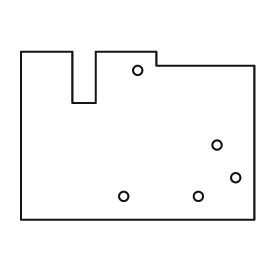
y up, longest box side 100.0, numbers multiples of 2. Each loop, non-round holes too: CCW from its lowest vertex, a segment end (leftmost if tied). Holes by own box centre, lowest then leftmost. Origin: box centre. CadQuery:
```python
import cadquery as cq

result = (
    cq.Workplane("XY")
    .moveTo(-50.0, -36.0)
    .lineTo(50.0, -36.0)
    .lineTo(50.0, 30.0)
    .lineTo(8.0, 30.0)
    .lineTo(8.0, 36.0)
    .lineTo(-18.0, 36.0)
    .lineTo(-18.0, 14.0)
    .lineTo(-28.0, 14.0)
    .lineTo(-28.0, 36.0)
    .lineTo(-50.0, 36.0)
    .close()
    .moveTo(-6.0, -26.0)
    .circle(2.0)
    .moveTo(26.0, -26.0)
    .circle(2.0)
    .moveTo(42.0, -18.0)
    .circle(2.0)
    .moveTo(34.0, -4.0)
    .circle(2.0)
    .moveTo(0.0, 28.0)
    .circle(2.0)
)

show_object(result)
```